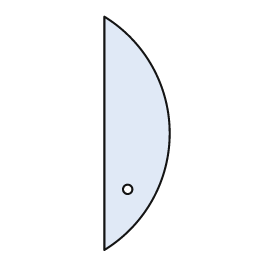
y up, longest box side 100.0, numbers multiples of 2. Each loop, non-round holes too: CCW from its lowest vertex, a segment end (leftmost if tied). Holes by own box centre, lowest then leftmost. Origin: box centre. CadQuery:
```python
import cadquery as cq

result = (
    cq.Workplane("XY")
    .moveTo(-14.0, -50.0)
    .threePointArc((14.0, 0.0), (-14.0, 50.0))
    .close()
    .moveTo(-4.0, -24.0)
    .circle(2.0)
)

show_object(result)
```